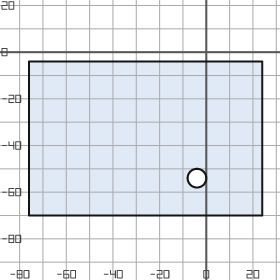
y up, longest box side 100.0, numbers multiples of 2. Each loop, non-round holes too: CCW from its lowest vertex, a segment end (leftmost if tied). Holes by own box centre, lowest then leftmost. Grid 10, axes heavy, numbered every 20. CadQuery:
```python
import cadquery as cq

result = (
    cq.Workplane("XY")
    .moveTo(-76.0, -70.0)
    .lineTo(24.0, -70.0)
    .lineTo(24.0, -4.0)
    .lineTo(-76.0, -4.0)
    .close()
    .moveTo(-4.0, -54.0)
    .circle(4.0)
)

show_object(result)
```